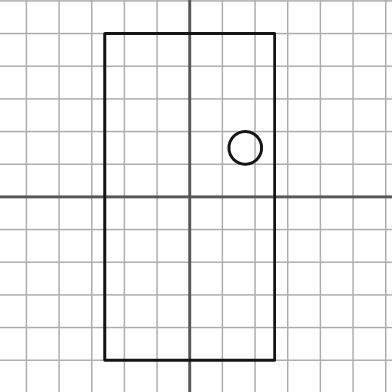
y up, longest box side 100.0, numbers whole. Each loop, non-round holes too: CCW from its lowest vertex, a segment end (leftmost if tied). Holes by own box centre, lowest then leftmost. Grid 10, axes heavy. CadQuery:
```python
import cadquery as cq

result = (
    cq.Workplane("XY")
    .moveTo(-26.0, -50.0)
    .lineTo(26.0, -50.0)
    .lineTo(26.0, 50.0)
    .lineTo(-26.0, 50.0)
    .close()
    .moveTo(17.0, 15.0)
    .circle(5.0)
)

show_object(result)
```